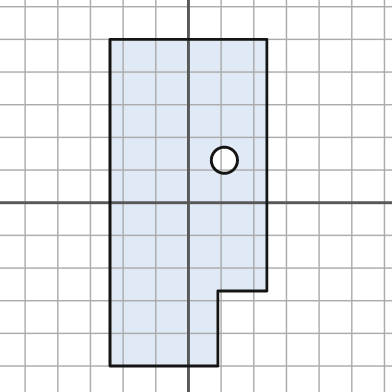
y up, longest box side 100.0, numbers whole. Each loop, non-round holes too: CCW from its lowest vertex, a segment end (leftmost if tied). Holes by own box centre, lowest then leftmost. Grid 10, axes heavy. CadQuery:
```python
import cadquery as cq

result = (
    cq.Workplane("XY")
    .moveTo(-24.0, -50.0)
    .lineTo(9.0, -50.0)
    .lineTo(9.0, -27.0)
    .lineTo(24.0, -27.0)
    .lineTo(24.0, 50.0)
    .lineTo(-24.0, 50.0)
    .close()
    .moveTo(11.0, 13.0)
    .circle(4.0)
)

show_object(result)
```